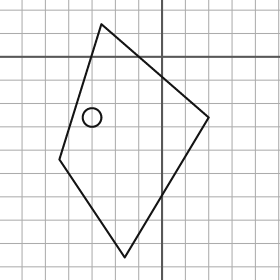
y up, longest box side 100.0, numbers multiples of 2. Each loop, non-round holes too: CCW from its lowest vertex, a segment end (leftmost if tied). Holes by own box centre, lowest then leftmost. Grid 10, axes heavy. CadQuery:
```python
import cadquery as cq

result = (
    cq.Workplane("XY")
    .moveTo(-16.0, -86.0)
    .lineTo(20.0, -26.0)
    .lineTo(-26.0, 14.0)
    .lineTo(-44.0, -44.0)
    .close()
    .moveTo(-30.0, -26.0)
    .circle(4.0)
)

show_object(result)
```